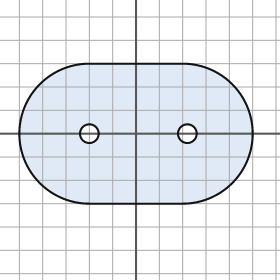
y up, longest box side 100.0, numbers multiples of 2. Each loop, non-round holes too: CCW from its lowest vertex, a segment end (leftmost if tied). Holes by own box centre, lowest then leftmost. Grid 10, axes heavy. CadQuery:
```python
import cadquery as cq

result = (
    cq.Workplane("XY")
    .moveTo(-20.0, -30.0)
    .lineTo(20.0, -30.0)
    .threePointArc((50.0, 0.0), (20.0, 30.0))
    .lineTo(-20.0, 30.0)
    .threePointArc((-50.0, 0.0), (-20.0, -30.0))
    .close()
    .moveTo(-20.0, 0.0)
    .circle(4.0)
    .moveTo(22.0, 0.0)
    .circle(4.0)
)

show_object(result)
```